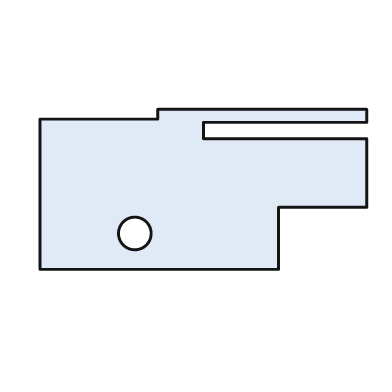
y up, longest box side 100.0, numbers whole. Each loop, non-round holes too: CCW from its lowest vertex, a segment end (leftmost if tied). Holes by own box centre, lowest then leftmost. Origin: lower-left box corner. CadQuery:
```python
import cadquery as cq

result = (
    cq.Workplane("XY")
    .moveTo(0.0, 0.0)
    .lineTo(73.0, 0.0)
    .lineTo(73.0, 19.0)
    .lineTo(100.0, 19.0)
    .lineTo(100.0, 40.0)
    .lineTo(50.0, 40.0)
    .lineTo(50.0, 45.0)
    .lineTo(100.0, 45.0)
    .lineTo(100.0, 49.0)
    .lineTo(36.0, 49.0)
    .lineTo(36.0, 46.0)
    .lineTo(0.0, 46.0)
    .close()
    .moveTo(29.0, 11.0)
    .circle(5.0)
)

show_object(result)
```